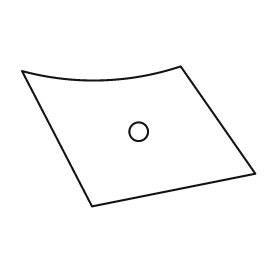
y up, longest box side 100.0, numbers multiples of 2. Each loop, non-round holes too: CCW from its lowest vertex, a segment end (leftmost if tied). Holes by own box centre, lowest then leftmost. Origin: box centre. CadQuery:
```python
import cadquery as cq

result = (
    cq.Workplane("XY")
    .moveTo(-20.0, -30.0)
    .lineTo(50.0, -16.0)
    .lineTo(18.0, 30.0)
    .threePointArc((-16.0, 24.0), (-50.0, 28.0))
    .close()
    .moveTo(0.0, 2.0)
    .circle(4.0)
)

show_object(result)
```